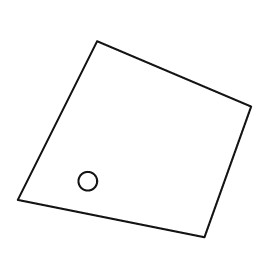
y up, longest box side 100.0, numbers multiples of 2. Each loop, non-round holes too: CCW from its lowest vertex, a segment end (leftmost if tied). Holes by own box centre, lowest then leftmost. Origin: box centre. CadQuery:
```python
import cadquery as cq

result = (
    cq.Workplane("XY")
    .moveTo(30.0, -42.0)
    .lineTo(50.0, 14.0)
    .lineTo(-16.0, 42.0)
    .lineTo(-50.0, -26.0)
    .close()
    .moveTo(-20.0, -18.0)
    .circle(4.0)
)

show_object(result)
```